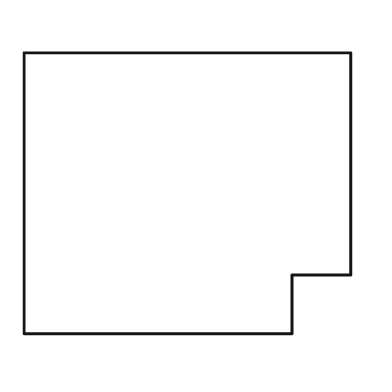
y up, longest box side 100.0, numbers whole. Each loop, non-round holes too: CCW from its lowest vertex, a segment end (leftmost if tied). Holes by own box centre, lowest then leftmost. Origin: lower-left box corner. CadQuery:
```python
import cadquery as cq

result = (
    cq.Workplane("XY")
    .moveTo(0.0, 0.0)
    .lineTo(82.0, 0.0)
    .lineTo(82.0, 18.0)
    .lineTo(100.0, 18.0)
    .lineTo(100.0, 86.0)
    .lineTo(0.0, 86.0)
    .close()
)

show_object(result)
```